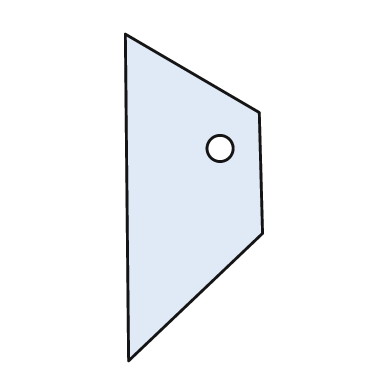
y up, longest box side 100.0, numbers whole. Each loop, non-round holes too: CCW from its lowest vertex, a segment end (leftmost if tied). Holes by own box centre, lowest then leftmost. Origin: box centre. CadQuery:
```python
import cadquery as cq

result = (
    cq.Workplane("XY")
    .moveTo(-20.0, -50.0)
    .lineTo(21.0, -11.0)
    .lineTo(20.0, 26.0)
    .lineTo(-21.0, 50.0)
    .close()
    .moveTo(8.0, 15.0)
    .circle(4.0)
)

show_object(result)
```